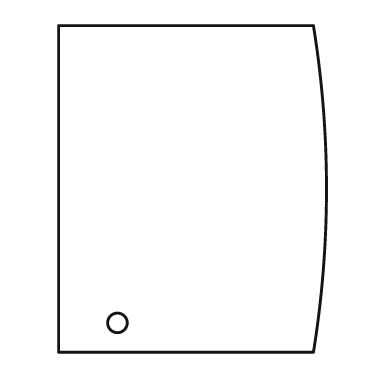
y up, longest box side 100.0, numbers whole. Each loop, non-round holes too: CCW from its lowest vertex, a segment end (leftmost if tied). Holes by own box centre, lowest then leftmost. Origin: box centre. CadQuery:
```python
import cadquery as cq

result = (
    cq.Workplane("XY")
    .moveTo(-41.0, -50.0)
    .lineTo(37.0, -50.0)
    .threePointArc((41.0, 0.0), (37.0, 50.0))
    .lineTo(-41.0, 50.0)
    .close()
    .moveTo(-23.0, -41.0)
    .circle(3.0)
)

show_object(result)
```